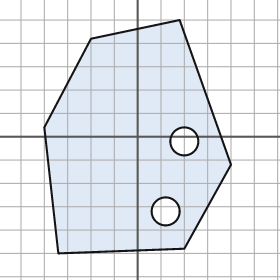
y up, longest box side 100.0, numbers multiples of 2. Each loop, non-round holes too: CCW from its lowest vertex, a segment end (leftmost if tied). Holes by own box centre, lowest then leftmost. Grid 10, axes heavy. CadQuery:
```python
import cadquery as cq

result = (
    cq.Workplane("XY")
    .moveTo(-34.0, -50.0)
    .lineTo(20.0, -48.0)
    .lineTo(40.0, -12.0)
    .lineTo(18.0, 50.0)
    .lineTo(-20.0, 42.0)
    .lineTo(-40.0, 4.0)
    .close()
    .moveTo(12.0, -32.0)
    .circle(6.0)
    .moveTo(20.0, -2.0)
    .circle(6.0)
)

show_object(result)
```